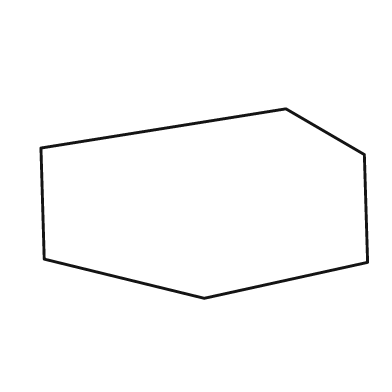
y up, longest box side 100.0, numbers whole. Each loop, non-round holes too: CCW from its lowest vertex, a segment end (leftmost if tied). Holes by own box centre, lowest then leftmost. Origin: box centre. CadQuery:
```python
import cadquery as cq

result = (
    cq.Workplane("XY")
    .moveTo(0.0, -29.0)
    .lineTo(50.0, -18.0)
    .lineTo(49.0, 15.0)
    .lineTo(25.0, 29.0)
    .lineTo(-50.0, 17.0)
    .lineTo(-49.0, -17.0)
    .close()
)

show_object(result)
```